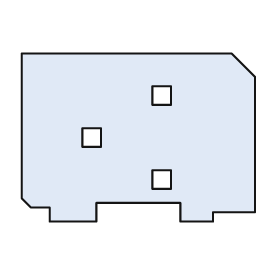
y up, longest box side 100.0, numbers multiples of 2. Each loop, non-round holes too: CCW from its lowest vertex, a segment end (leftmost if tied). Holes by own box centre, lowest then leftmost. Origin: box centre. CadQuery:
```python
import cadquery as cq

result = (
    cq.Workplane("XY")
    .moveTo(-38.0, -36.0)
    .lineTo(-18.0, -36.0)
    .lineTo(-18.0, -28.0)
    .lineTo(18.0, -28.0)
    .lineTo(18.0, -36.0)
    .lineTo(32.0, -36.0)
    .lineTo(32.0, -32.0)
    .lineTo(50.0, -32.0)
    .lineTo(50.0, 26.0)
    .lineTo(40.0, 36.0)
    .lineTo(-50.0, 36.0)
    .lineTo(-50.0, -26.0)
    .lineTo(-46.0, -30.0)
    .lineTo(-38.0, -30.0)
    .close()
    .moveTo(6.0, -22.0)
    .lineTo(14.0, -22.0)
    .lineTo(14.0, -14.0)
    .lineTo(6.0, -14.0)
    .close()
    .moveTo(-24.0, -4.0)
    .lineTo(-16.0, -4.0)
    .lineTo(-16.0, 4.0)
    .lineTo(-24.0, 4.0)
    .close()
    .moveTo(6.0, 14.0)
    .lineTo(14.0, 14.0)
    .lineTo(14.0, 22.0)
    .lineTo(6.0, 22.0)
    .close()
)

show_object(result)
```